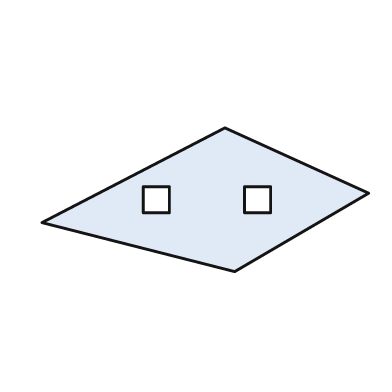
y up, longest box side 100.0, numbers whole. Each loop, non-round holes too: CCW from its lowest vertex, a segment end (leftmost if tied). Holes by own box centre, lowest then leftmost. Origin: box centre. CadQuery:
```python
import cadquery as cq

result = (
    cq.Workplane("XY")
    .moveTo(9.0, -22.0)
    .lineTo(50.0, 2.0)
    .lineTo(6.0, 22.0)
    .lineTo(-50.0, -7.0)
    .close()
    .moveTo(-19.0, -4.0)
    .lineTo(-11.0, -4.0)
    .lineTo(-11.0, 4.0)
    .lineTo(-19.0, 4.0)
    .close()
    .moveTo(12.0, -4.0)
    .lineTo(20.0, -4.0)
    .lineTo(20.0, 4.0)
    .lineTo(12.0, 4.0)
    .close()
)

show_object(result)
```